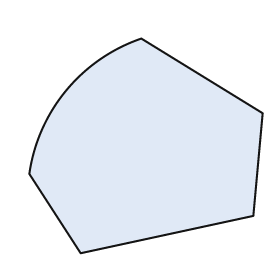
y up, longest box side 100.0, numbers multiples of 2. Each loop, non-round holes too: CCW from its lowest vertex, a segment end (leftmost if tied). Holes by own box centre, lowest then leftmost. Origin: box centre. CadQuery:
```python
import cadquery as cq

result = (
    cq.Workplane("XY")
    .moveTo(-28.0, -46.0)
    .lineTo(46.0, -30.0)
    .lineTo(50.0, 14.0)
    .lineTo(-2.0, 46.0)
    .threePointArc((-34.0, 24.0), (-50.0, -12.0))
    .close()
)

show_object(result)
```